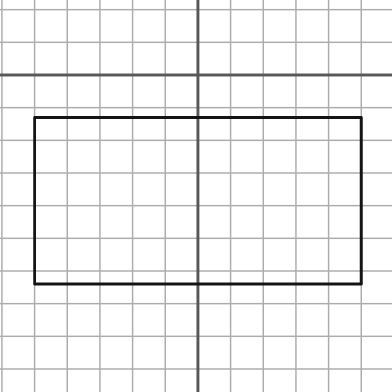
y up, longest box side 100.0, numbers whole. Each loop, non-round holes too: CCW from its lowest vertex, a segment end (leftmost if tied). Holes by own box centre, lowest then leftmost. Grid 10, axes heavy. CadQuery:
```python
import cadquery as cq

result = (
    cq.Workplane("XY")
    .moveTo(-50.0, -64.0)
    .lineTo(50.0, -64.0)
    .lineTo(50.0, -13.0)
    .lineTo(-50.0, -13.0)
    .close()
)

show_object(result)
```